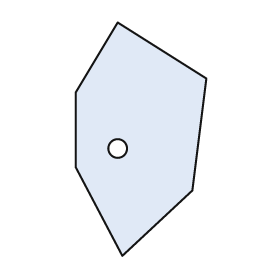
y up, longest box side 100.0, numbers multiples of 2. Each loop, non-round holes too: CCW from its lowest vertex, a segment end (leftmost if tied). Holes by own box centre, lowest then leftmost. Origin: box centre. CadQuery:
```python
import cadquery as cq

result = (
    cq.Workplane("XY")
    .moveTo(-8.0, -50.0)
    .lineTo(22.0, -22.0)
    .lineTo(28.0, 26.0)
    .lineTo(-10.0, 50.0)
    .lineTo(-28.0, 20.0)
    .lineTo(-28.0, -12.0)
    .close()
    .moveTo(-10.0, -4.0)
    .circle(4.0)
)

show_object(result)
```